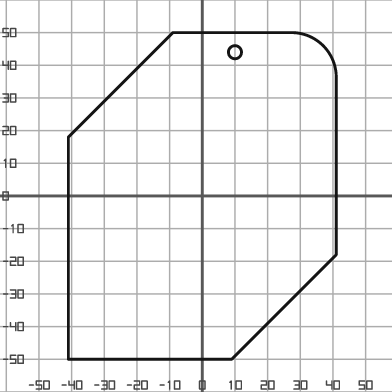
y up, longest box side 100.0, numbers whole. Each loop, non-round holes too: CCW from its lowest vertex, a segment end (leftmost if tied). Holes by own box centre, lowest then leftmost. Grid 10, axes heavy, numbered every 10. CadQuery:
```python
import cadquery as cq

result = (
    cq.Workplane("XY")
    .moveTo(-41.0, -50.0)
    .lineTo(9.0, -50.0)
    .lineTo(41.0, -18.0)
    .lineTo(41.0, 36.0)
    .threePointArc((37.0, 46.0), (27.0, 50.0))
    .lineTo(-9.0, 50.0)
    .lineTo(-41.0, 18.0)
    .close()
    .moveTo(10.0, 44.0)
    .circle(2.0)
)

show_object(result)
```